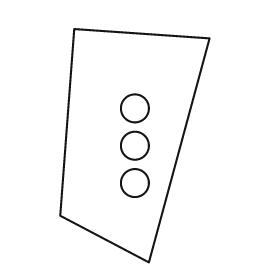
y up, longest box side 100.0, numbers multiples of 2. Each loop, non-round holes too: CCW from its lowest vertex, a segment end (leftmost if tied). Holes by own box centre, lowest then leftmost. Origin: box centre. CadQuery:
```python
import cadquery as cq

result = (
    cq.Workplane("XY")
    .moveTo(6.0, -50.0)
    .lineTo(32.0, 46.0)
    .lineTo(-26.0, 50.0)
    .lineTo(-32.0, -30.0)
    .close()
    .moveTo(0.0, -16.0)
    .circle(6.0)
    .moveTo(0.0, 0.0)
    .circle(6.0)
    .moveTo(0.0, 16.0)
    .circle(6.0)
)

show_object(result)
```